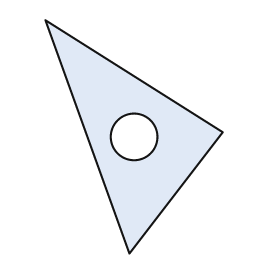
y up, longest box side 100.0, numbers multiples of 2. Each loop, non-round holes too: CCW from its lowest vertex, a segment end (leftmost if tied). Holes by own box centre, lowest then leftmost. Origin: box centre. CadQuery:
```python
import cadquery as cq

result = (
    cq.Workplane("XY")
    .moveTo(-2.0, -50.0)
    .lineTo(38.0, 2.0)
    .lineTo(-38.0, 50.0)
    .close()
    .moveTo(0.0, 0.0)
    .circle(10.0)
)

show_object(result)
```